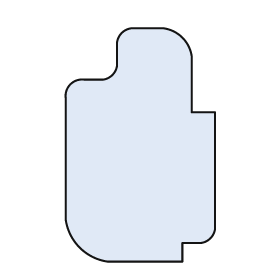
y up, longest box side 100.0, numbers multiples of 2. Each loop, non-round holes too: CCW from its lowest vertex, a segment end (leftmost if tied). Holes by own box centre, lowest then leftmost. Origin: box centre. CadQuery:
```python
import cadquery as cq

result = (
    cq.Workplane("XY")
    .moveTo(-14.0, -50.0)
    .lineTo(18.0, -50.0)
    .lineTo(18.0, -42.0)
    .lineTo(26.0, -42.0)
    .threePointArc((30.0, -40.0), (32.0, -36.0))
    .lineTo(32.0, 14.0)
    .lineTo(22.0, 14.0)
    .lineTo(22.0, 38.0)
    .threePointArc((18.0, 46.0), (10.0, 50.0))
    .lineTo(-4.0, 50.0)
    .threePointArc((-8.0, 48.0), (-10.0, 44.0))
    .lineTo(-10.0, 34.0)
    .threePointArc((-12.0, 30.0), (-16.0, 28.0))
    .lineTo(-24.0, 28.0)
    .threePointArc((-30.0, 26.0), (-32.0, 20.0))
    .lineTo(-32.0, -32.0)
    .threePointArc((-26.0, -44.0), (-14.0, -50.0))
    .close()
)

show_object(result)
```